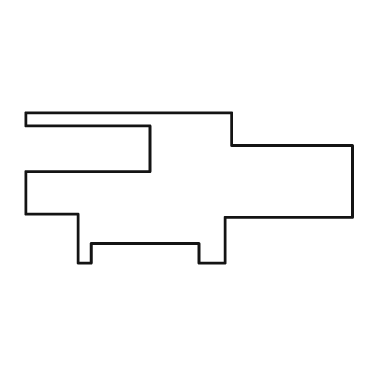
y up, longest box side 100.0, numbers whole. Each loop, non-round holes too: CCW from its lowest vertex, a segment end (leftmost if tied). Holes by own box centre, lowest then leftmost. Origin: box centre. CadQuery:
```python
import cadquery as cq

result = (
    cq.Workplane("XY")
    .moveTo(-34.0, -23.0)
    .lineTo(-30.0, -23.0)
    .lineTo(-30.0, -17.0)
    .lineTo(3.0, -17.0)
    .lineTo(3.0, -23.0)
    .lineTo(11.0, -23.0)
    .lineTo(11.0, -9.0)
    .lineTo(50.0, -9.0)
    .lineTo(50.0, 13.0)
    .lineTo(13.0, 13.0)
    .lineTo(13.0, 23.0)
    .lineTo(-50.0, 23.0)
    .lineTo(-50.0, 19.0)
    .lineTo(-12.0, 19.0)
    .lineTo(-12.0, 5.0)
    .lineTo(-50.0, 5.0)
    .lineTo(-50.0, -8.0)
    .lineTo(-34.0, -8.0)
    .close()
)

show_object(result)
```